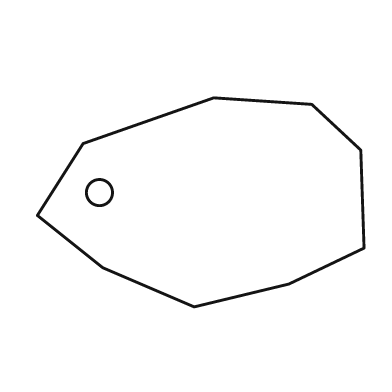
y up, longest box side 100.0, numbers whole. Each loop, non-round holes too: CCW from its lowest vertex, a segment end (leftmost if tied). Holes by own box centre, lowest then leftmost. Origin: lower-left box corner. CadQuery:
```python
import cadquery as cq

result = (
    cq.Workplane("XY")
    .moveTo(48.0, 0.0)
    .lineTo(77.0, 7.0)
    .lineTo(100.0, 18.0)
    .lineTo(99.0, 48.0)
    .lineTo(84.0, 62.0)
    .lineTo(54.0, 64.0)
    .lineTo(14.0, 50.0)
    .lineTo(0.0, 28.0)
    .lineTo(20.0, 12.0)
    .close()
    .moveTo(19.0, 35.0)
    .circle(4.0)
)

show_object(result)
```